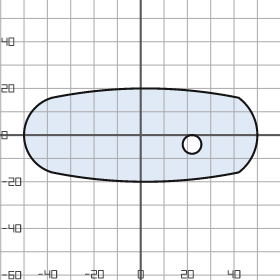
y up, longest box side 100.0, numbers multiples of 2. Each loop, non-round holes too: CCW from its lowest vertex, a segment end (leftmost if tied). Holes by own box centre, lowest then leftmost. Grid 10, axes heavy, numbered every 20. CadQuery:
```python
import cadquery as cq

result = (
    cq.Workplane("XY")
    .moveTo(-38.0, -16.0)
    .threePointArc((2.0, -20.0), (42.0, -16.0))
    .threePointArc((50.0, 0.0), (42.0, 16.0))
    .threePointArc((2.0, 20.0), (-38.0, 16.0))
    .threePointArc((-50.0, 0.0), (-38.0, -16.0))
    .close()
    .moveTo(22.0, -4.0)
    .circle(4.0)
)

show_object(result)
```